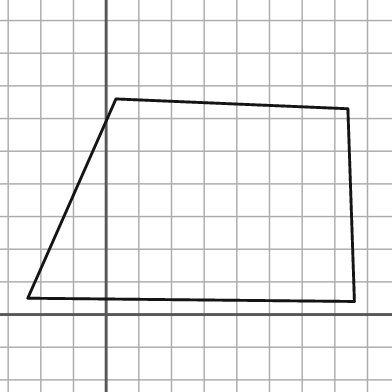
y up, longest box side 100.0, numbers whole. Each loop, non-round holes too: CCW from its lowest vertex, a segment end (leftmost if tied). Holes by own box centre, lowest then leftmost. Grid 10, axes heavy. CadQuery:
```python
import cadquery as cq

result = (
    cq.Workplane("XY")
    .moveTo(76.0, 4.0)
    .lineTo(74.0, 63.0)
    .lineTo(3.0, 66.0)
    .lineTo(-24.0, 5.0)
    .close()
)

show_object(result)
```